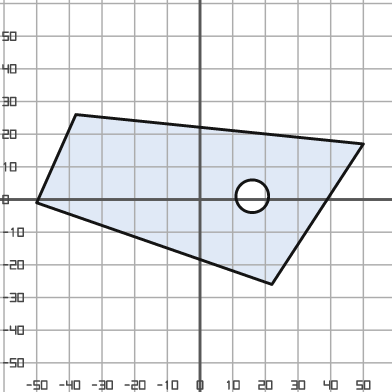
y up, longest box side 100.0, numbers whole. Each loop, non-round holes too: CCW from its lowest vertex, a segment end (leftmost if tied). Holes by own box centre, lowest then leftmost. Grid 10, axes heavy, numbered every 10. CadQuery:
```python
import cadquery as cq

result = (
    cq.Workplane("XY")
    .moveTo(22.0, -26.0)
    .lineTo(50.0, 17.0)
    .lineTo(-38.0, 26.0)
    .lineTo(-50.0, -1.0)
    .close()
    .moveTo(16.0, 1.0)
    .circle(5.0)
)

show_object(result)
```